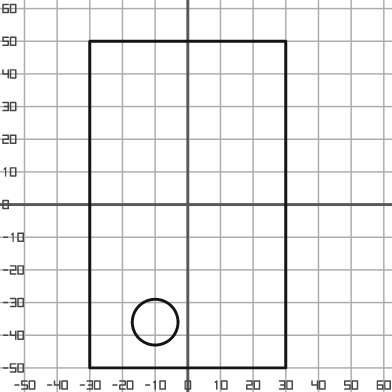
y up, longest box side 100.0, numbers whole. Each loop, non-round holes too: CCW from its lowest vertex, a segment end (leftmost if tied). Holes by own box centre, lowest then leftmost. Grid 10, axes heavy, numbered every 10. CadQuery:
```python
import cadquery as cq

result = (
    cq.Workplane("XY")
    .moveTo(-30.0, -50.0)
    .lineTo(30.0, -50.0)
    .lineTo(30.0, 50.0)
    .lineTo(-30.0, 50.0)
    .close()
    .moveTo(-10.0, -36.0)
    .circle(7.0)
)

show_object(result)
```